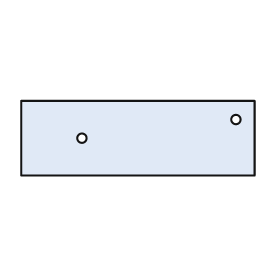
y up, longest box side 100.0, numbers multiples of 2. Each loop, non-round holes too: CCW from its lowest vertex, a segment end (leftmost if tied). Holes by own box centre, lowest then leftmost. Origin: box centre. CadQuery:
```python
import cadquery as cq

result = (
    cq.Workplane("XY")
    .moveTo(-50.0, -16.0)
    .lineTo(50.0, -16.0)
    .lineTo(50.0, 16.0)
    .lineTo(-50.0, 16.0)
    .close()
    .moveTo(-24.0, 0.0)
    .circle(2.0)
    .moveTo(42.0, 8.0)
    .circle(2.0)
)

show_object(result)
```